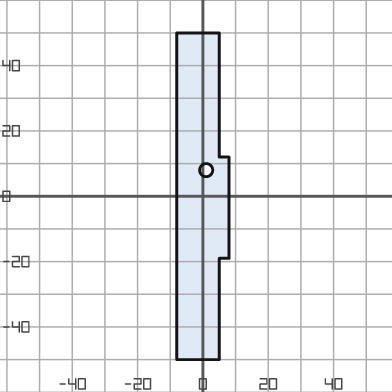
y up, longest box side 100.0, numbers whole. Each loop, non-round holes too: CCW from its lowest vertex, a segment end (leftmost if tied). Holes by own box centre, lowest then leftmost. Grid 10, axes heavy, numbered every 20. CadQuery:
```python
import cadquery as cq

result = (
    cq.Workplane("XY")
    .moveTo(-8.0, -50.0)
    .lineTo(5.0, -50.0)
    .lineTo(5.0, -19.0)
    .lineTo(8.0, -19.0)
    .lineTo(8.0, 12.0)
    .lineTo(5.0, 12.0)
    .lineTo(5.0, 50.0)
    .lineTo(-8.0, 50.0)
    .close()
    .moveTo(1.0, 8.0)
    .circle(2.0)
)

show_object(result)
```